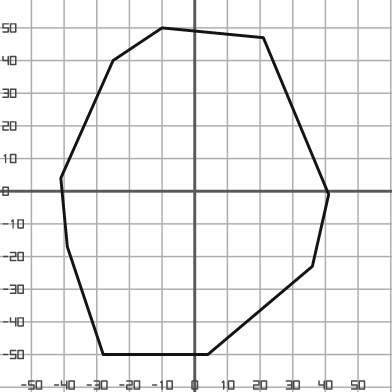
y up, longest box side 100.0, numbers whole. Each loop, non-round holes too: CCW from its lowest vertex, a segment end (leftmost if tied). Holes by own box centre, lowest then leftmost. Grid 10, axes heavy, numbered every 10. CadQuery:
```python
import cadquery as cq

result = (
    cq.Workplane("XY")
    .moveTo(-28.0, -50.0)
    .lineTo(4.0, -50.0)
    .lineTo(36.0, -23.0)
    .lineTo(41.0, -1.0)
    .lineTo(21.0, 47.0)
    .lineTo(-10.0, 50.0)
    .lineTo(-25.0, 40.0)
    .lineTo(-41.0, 4.0)
    .lineTo(-39.0, -17.0)
    .close()
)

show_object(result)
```